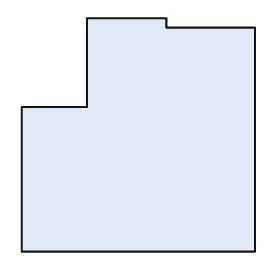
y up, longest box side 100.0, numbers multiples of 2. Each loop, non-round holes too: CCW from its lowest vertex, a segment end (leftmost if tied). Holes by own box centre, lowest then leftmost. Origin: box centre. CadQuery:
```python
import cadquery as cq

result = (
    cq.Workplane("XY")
    .moveTo(-50.0, -50.0)
    .lineTo(50.0, -50.0)
    .lineTo(50.0, 46.0)
    .lineTo(12.0, 46.0)
    .lineTo(12.0, 50.0)
    .lineTo(-22.0, 50.0)
    .lineTo(-22.0, 12.0)
    .lineTo(-50.0, 12.0)
    .close()
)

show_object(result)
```